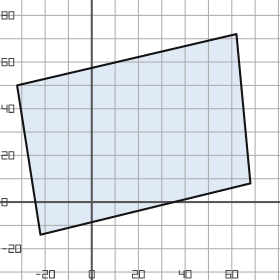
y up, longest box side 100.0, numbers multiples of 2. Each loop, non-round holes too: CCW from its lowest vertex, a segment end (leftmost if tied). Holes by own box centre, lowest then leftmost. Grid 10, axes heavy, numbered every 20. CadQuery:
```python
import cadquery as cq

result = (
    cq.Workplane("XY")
    .moveTo(-22.0, -14.0)
    .lineTo(68.0, 8.0)
    .lineTo(62.0, 72.0)
    .lineTo(-32.0, 50.0)
    .close()
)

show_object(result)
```